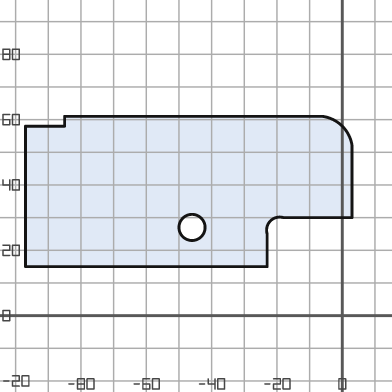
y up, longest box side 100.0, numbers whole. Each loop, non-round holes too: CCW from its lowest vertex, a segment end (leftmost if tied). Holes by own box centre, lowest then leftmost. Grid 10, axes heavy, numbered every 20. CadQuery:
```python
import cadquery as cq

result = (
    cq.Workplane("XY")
    .moveTo(-97.0, 15.0)
    .lineTo(-23.0, 15.0)
    .lineTo(-23.0, 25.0)
    .threePointArc((-22.0, 29.0), (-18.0, 30.0))
    .lineTo(3.0, 30.0)
    .lineTo(3.0, 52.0)
    .threePointArc((0.0, 58.0), (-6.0, 61.0))
    .lineTo(-85.0, 61.0)
    .lineTo(-85.0, 58.0)
    .lineTo(-97.0, 58.0)
    .close()
    .moveTo(-46.0, 27.0)
    .circle(4.0)
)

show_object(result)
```